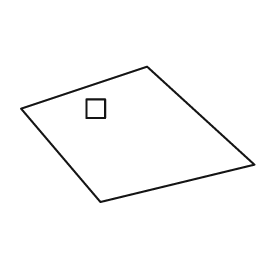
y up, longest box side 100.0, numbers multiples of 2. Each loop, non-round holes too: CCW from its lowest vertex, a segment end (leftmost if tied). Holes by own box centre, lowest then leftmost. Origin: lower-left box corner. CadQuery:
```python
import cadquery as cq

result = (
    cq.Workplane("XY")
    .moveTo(34.0, 0.0)
    .lineTo(100.0, 16.0)
    .lineTo(54.0, 58.0)
    .lineTo(0.0, 40.0)
    .close()
    .moveTo(28.0, 36.0)
    .lineTo(36.0, 36.0)
    .lineTo(36.0, 44.0)
    .lineTo(28.0, 44.0)
    .close()
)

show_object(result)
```